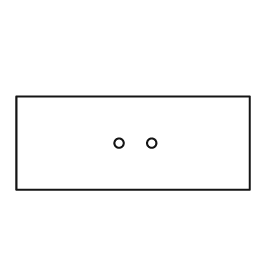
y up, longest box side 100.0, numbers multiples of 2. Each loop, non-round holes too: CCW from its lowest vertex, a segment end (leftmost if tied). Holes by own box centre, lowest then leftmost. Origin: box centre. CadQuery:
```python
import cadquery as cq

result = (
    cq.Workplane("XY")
    .moveTo(-50.0, -20.0)
    .lineTo(50.0, -20.0)
    .lineTo(50.0, 20.0)
    .lineTo(-50.0, 20.0)
    .close()
    .moveTo(-6.0, 0.0)
    .circle(2.0)
    .moveTo(8.0, 0.0)
    .circle(2.0)
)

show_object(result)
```